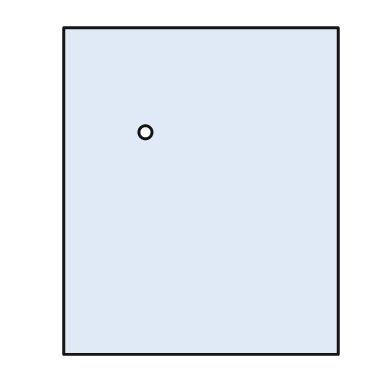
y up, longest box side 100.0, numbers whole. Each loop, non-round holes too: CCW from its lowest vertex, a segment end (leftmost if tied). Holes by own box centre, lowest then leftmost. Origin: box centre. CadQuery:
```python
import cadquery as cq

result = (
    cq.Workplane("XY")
    .moveTo(-42.0, -50.0)
    .lineTo(42.0, -50.0)
    .lineTo(42.0, 50.0)
    .lineTo(-42.0, 50.0)
    .close()
    .moveTo(-17.0, 18.0)
    .circle(2.0)
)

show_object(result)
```